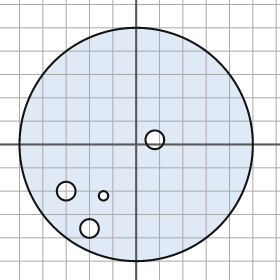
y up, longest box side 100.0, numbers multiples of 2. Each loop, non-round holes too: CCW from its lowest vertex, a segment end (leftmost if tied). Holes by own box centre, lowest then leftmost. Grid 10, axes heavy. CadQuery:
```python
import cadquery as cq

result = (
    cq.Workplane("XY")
    .moveTo(0.0, 0.0)
    .circle(50.0)
    .moveTo(-20.0, -36.0)
    .circle(4.0)
    .moveTo(-14.0, -22.0)
    .circle(2.0)
    .moveTo(-30.0, -20.0)
    .circle(4.0)
    .moveTo(8.0, 2.0)
    .circle(4.0)
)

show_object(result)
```